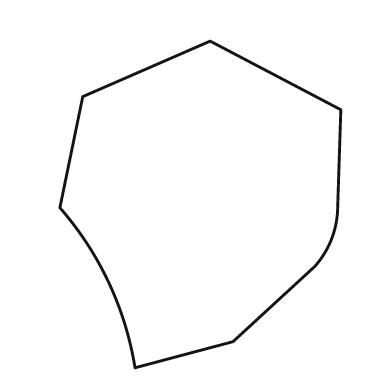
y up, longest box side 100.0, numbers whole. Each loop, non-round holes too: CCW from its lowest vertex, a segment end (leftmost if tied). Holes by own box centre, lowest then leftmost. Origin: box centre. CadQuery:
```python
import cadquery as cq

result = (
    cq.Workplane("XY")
    .moveTo(-20.0, -50.0)
    .lineTo(10.0, -42.0)
    .lineTo(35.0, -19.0)
    .threePointArc((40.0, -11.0), (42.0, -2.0))
    .lineTo(43.0, 29.0)
    .lineTo(3.0, 50.0)
    .lineTo(-36.0, 33.0)
    .lineTo(-43.0, -1.0)
    .threePointArc((-28.0, -24.0), (-20.0, -50.0))
    .close()
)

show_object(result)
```